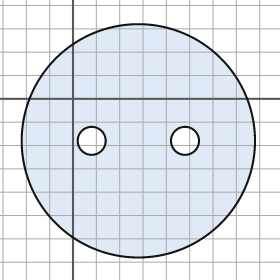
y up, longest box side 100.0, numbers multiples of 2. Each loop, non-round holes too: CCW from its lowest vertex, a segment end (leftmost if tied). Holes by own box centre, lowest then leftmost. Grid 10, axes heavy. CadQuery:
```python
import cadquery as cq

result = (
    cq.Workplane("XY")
    .moveTo(28.0, -18.0)
    .circle(50.0)
    .moveTo(8.0, -18.0)
    .circle(6.0)
    .moveTo(48.0, -18.0)
    .circle(6.0)
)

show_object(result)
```